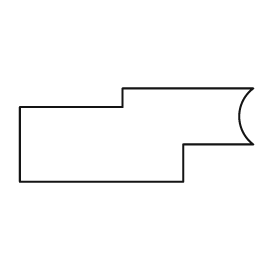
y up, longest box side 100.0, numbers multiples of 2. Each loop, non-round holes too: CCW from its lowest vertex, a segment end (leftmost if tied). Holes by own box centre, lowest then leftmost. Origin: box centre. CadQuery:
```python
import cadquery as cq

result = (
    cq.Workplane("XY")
    .moveTo(-50.0, -20.0)
    .lineTo(20.0, -20.0)
    .lineTo(20.0, -4.0)
    .lineTo(50.0, -4.0)
    .threePointArc((44.0, 8.0), (50.0, 20.0))
    .lineTo(-6.0, 20.0)
    .lineTo(-6.0, 12.0)
    .lineTo(-50.0, 12.0)
    .close()
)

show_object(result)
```